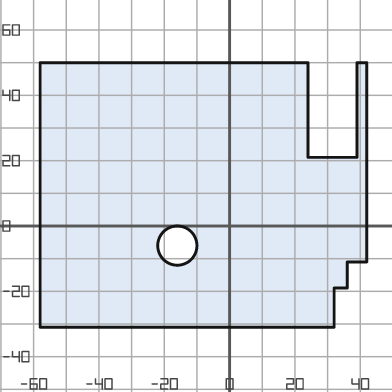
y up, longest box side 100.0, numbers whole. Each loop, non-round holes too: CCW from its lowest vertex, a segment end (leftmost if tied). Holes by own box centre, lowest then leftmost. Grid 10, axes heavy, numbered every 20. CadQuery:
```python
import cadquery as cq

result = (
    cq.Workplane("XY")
    .moveTo(-58.0, -31.0)
    .lineTo(32.0, -31.0)
    .lineTo(32.0, -19.0)
    .lineTo(36.0, -19.0)
    .lineTo(36.0, -11.0)
    .lineTo(42.0, -11.0)
    .lineTo(42.0, 50.0)
    .lineTo(39.0, 50.0)
    .lineTo(39.0, 21.0)
    .lineTo(24.0, 21.0)
    .lineTo(24.0, 50.0)
    .lineTo(-58.0, 50.0)
    .close()
    .moveTo(-16.0, -6.0)
    .circle(6.0)
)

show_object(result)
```